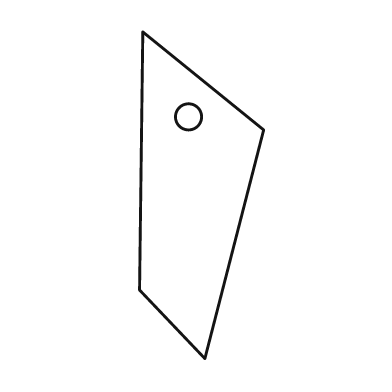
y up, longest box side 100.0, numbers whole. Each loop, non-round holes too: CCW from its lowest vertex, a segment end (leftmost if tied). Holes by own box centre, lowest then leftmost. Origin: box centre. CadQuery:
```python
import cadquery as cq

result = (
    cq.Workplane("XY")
    .moveTo(1.0, -50.0)
    .lineTo(19.0, 20.0)
    .lineTo(-18.0, 50.0)
    .lineTo(-19.0, -29.0)
    .close()
    .moveTo(-4.0, 24.0)
    .circle(4.0)
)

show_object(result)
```